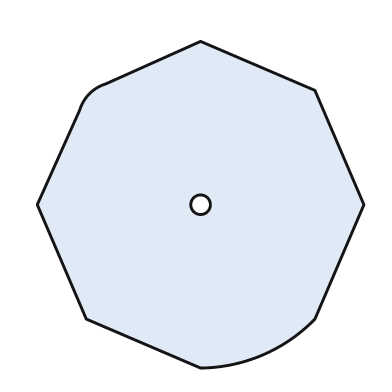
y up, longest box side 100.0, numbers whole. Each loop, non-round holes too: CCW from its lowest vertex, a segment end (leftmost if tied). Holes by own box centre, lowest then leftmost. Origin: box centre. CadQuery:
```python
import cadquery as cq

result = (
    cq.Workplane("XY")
    .moveTo(0.0, -50.0)
    .threePointArc((19.0, -46.0), (35.0, -35.0))
    .lineTo(50.0, 0.0)
    .lineTo(35.0, 35.0)
    .lineTo(0.0, 50.0)
    .lineTo(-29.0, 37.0)
    .threePointArc((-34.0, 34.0), (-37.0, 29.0))
    .lineTo(-50.0, 0.0)
    .lineTo(-35.0, -35.0)
    .close()
    .moveTo(0.0, 0.0)
    .circle(3.0)
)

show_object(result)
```